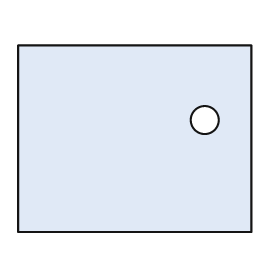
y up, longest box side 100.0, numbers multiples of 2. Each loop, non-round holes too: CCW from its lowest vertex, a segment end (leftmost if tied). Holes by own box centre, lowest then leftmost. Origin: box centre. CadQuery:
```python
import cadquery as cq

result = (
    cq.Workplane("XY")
    .moveTo(-50.0, -40.0)
    .lineTo(50.0, -40.0)
    .lineTo(50.0, 40.0)
    .lineTo(-50.0, 40.0)
    .close()
    .moveTo(30.0, 8.0)
    .circle(6.0)
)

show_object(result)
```